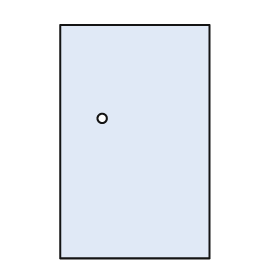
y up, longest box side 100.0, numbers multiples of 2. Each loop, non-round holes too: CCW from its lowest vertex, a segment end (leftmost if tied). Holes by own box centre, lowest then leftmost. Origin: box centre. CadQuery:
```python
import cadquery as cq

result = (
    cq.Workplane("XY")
    .moveTo(-32.0, -50.0)
    .lineTo(32.0, -50.0)
    .lineTo(32.0, 50.0)
    .lineTo(-32.0, 50.0)
    .close()
    .moveTo(-14.0, 10.0)
    .circle(2.0)
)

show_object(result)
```